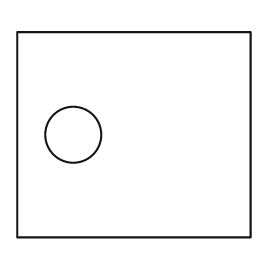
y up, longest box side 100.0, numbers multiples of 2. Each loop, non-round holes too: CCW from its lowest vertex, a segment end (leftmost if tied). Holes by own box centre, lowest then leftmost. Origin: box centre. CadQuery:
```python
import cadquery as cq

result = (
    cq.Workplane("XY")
    .moveTo(-50.0, -44.0)
    .lineTo(50.0, -44.0)
    .lineTo(50.0, 44.0)
    .lineTo(-50.0, 44.0)
    .close()
    .moveTo(-26.0, 0.0)
    .circle(12.0)
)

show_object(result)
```